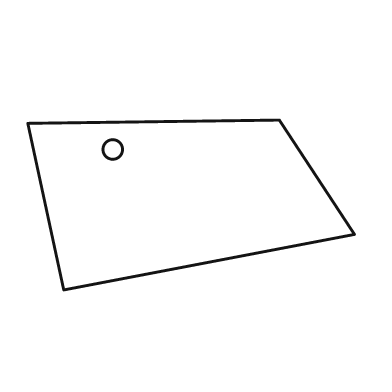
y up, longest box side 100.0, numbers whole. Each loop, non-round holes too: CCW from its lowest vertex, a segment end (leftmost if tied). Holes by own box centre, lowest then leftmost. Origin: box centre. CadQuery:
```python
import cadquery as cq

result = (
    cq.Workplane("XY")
    .moveTo(-39.0, -26.0)
    .lineTo(50.0, -9.0)
    .lineTo(27.0, 26.0)
    .lineTo(-50.0, 25.0)
    .close()
    .moveTo(-24.0, 17.0)
    .circle(3.0)
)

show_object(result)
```